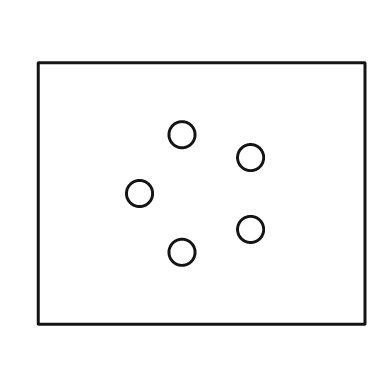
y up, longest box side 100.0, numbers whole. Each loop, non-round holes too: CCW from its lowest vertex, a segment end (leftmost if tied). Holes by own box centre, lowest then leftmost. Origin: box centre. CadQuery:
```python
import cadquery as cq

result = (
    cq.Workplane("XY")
    .moveTo(-50.0, -40.0)
    .lineTo(50.0, -40.0)
    .lineTo(50.0, 40.0)
    .lineTo(-50.0, 40.0)
    .close()
    .moveTo(-6.0, -18.0)
    .circle(4.0)
    .moveTo(15.0, -11.0)
    .circle(4.0)
    .moveTo(-19.0, 0.0)
    .circle(4.0)
    .moveTo(15.0, 11.0)
    .circle(4.0)
    .moveTo(-6.0, 18.0)
    .circle(4.0)
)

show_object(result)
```